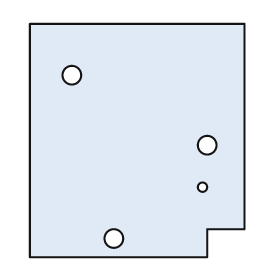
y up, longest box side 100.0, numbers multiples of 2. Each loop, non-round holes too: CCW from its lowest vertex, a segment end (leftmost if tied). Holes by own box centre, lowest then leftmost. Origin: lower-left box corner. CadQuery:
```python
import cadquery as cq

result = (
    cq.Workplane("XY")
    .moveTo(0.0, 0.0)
    .lineTo(76.0, 0.0)
    .lineTo(76.0, 12.0)
    .lineTo(92.0, 12.0)
    .lineTo(92.0, 100.0)
    .lineTo(0.0, 100.0)
    .close()
    .moveTo(36.0, 8.0)
    .circle(4.0)
    .moveTo(74.0, 30.0)
    .circle(2.0)
    .moveTo(76.0, 48.0)
    .circle(4.0)
    .moveTo(18.0, 78.0)
    .circle(4.0)
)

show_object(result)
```